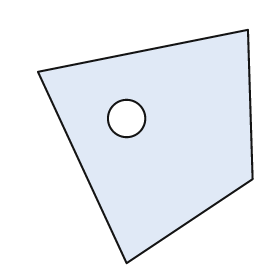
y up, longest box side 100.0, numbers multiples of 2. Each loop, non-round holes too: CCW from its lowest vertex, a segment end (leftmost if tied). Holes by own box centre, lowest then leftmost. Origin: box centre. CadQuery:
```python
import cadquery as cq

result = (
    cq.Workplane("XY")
    .moveTo(-8.0, -50.0)
    .lineTo(46.0, -14.0)
    .lineTo(44.0, 50.0)
    .lineTo(-46.0, 32.0)
    .close()
    .moveTo(-8.0, 12.0)
    .circle(8.0)
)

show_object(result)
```